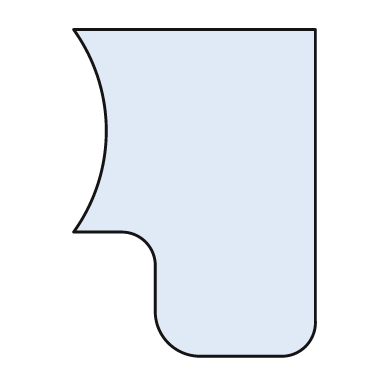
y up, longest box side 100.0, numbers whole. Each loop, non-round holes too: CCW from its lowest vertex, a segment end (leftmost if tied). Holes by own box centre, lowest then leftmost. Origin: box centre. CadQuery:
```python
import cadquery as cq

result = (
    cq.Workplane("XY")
    .moveTo(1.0, -50.0)
    .lineTo(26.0, -50.0)
    .threePointArc((34.0, -47.0), (37.0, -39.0))
    .lineTo(37.0, 50.0)
    .lineTo(-37.0, 50.0)
    .threePointArc((-27.0, 19.0), (-37.0, -12.0))
    .lineTo(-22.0, -12.0)
    .threePointArc((-15.0, -15.0), (-12.0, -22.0))
    .lineTo(-12.0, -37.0)
    .threePointArc((-8.0, -46.0), (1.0, -50.0))
    .close()
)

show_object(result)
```